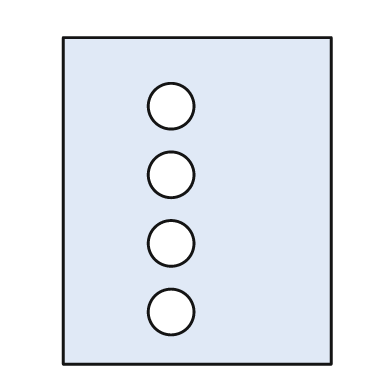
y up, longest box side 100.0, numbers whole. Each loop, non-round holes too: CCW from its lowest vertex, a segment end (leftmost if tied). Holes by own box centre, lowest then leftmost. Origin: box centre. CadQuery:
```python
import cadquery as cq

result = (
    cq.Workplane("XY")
    .moveTo(-41.0, -50.0)
    .lineTo(41.0, -50.0)
    .lineTo(41.0, 50.0)
    .lineTo(-41.0, 50.0)
    .close()
    .moveTo(-8.0, -34.0)
    .circle(7.0)
    .moveTo(-8.0, -13.0)
    .circle(7.0)
    .moveTo(-8.0, 8.0)
    .circle(7.0)
    .moveTo(-8.0, 29.0)
    .circle(7.0)
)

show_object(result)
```